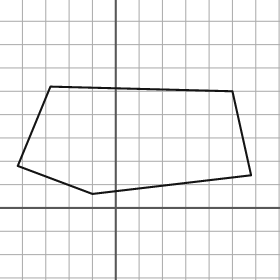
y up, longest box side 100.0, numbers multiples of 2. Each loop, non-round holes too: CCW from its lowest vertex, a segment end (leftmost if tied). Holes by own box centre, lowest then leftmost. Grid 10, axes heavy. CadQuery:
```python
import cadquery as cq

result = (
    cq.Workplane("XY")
    .moveTo(-10.0, 6.0)
    .lineTo(58.0, 14.0)
    .lineTo(50.0, 50.0)
    .lineTo(-28.0, 52.0)
    .lineTo(-42.0, 18.0)
    .close()
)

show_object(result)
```